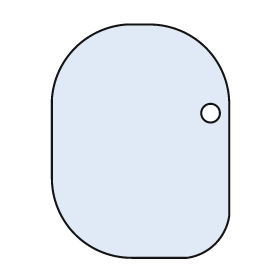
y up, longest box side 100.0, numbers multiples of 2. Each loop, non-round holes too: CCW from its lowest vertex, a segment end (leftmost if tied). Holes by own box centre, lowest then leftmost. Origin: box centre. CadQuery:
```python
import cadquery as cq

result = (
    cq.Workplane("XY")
    .moveTo(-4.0, -50.0)
    .lineTo(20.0, -50.0)
    .threePointArc((32.0, -44.0), (38.0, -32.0))
    .lineTo(38.0, 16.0)
    .threePointArc((28.0, 40.0), (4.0, 50.0))
    .lineTo(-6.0, 50.0)
    .threePointArc((-28.0, 40.0), (-38.0, 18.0))
    .lineTo(-38.0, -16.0)
    .threePointArc((-28.0, -40.0), (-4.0, -50.0))
    .close()
    .moveTo(30.0, 12.0)
    .circle(4.0)
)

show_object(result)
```